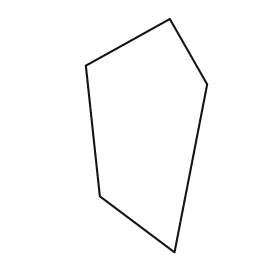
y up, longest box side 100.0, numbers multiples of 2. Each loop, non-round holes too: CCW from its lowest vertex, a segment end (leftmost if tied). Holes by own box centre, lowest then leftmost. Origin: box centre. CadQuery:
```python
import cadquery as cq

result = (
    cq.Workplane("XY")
    .moveTo(12.0, -50.0)
    .lineTo(26.0, 22.0)
    .lineTo(10.0, 50.0)
    .lineTo(-26.0, 30.0)
    .lineTo(-20.0, -26.0)
    .close()
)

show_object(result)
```